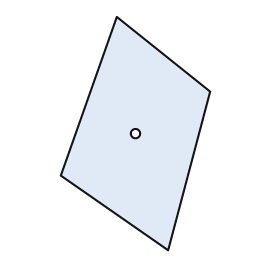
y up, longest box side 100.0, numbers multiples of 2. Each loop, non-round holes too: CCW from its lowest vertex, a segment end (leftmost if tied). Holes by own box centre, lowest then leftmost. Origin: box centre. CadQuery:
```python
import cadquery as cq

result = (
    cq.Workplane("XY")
    .moveTo(14.0, -50.0)
    .lineTo(32.0, 18.0)
    .lineTo(-8.0, 50.0)
    .lineTo(-32.0, -18.0)
    .close()
    .moveTo(0.0, 0.0)
    .circle(2.0)
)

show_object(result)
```